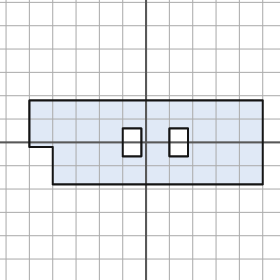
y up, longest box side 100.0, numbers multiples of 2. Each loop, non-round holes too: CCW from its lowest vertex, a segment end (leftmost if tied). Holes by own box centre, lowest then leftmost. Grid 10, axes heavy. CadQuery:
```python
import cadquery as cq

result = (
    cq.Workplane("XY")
    .moveTo(-40.0, -18.0)
    .lineTo(50.0, -18.0)
    .lineTo(50.0, 18.0)
    .lineTo(-50.0, 18.0)
    .lineTo(-50.0, -2.0)
    .lineTo(-40.0, -2.0)
    .close()
    .moveTo(-10.0, -6.0)
    .lineTo(-2.0, -6.0)
    .lineTo(-2.0, 6.0)
    .lineTo(-10.0, 6.0)
    .close()
    .moveTo(10.0, -6.0)
    .lineTo(18.0, -6.0)
    .lineTo(18.0, 6.0)
    .lineTo(10.0, 6.0)
    .close()
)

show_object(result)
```